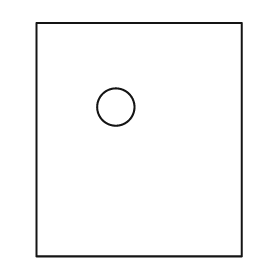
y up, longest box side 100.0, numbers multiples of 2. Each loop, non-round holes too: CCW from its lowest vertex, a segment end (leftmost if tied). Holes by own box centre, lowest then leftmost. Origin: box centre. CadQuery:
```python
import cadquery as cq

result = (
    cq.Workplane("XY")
    .moveTo(-44.0, -50.0)
    .lineTo(44.0, -50.0)
    .lineTo(44.0, 50.0)
    .lineTo(-44.0, 50.0)
    .close()
    .moveTo(-10.0, 14.0)
    .circle(8.0)
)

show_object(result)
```